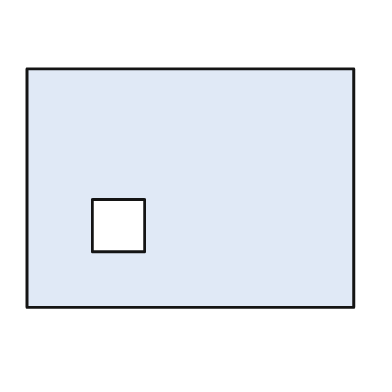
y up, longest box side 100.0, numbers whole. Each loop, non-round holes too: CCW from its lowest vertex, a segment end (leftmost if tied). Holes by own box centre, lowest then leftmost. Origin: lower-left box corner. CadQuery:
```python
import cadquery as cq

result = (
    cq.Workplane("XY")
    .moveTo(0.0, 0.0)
    .lineTo(100.0, 0.0)
    .lineTo(100.0, 73.0)
    .lineTo(0.0, 73.0)
    .close()
    .moveTo(20.0, 17.0)
    .lineTo(36.0, 17.0)
    .lineTo(36.0, 33.0)
    .lineTo(20.0, 33.0)
    .close()
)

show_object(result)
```